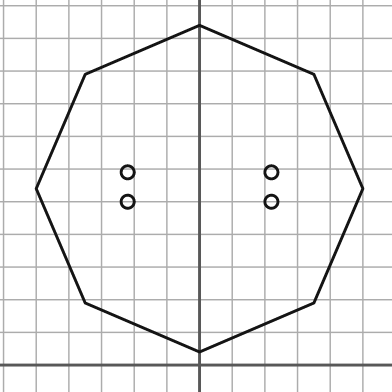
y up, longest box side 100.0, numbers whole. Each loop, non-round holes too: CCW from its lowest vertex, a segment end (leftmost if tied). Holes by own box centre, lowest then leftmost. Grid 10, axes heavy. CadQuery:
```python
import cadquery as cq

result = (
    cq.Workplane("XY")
    .moveTo(0.0, 4.0)
    .lineTo(35.0, 19.0)
    .lineTo(50.0, 54.0)
    .lineTo(35.0, 89.0)
    .lineTo(0.0, 104.0)
    .lineTo(-35.0, 89.0)
    .lineTo(-50.0, 54.0)
    .lineTo(-35.0, 19.0)
    .close()
    .moveTo(-22.0, 50.0)
    .circle(2.0)
    .moveTo(22.0, 50.0)
    .circle(2.0)
    .moveTo(-22.0, 59.0)
    .circle(2.0)
    .moveTo(22.0, 59.0)
    .circle(2.0)
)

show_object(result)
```